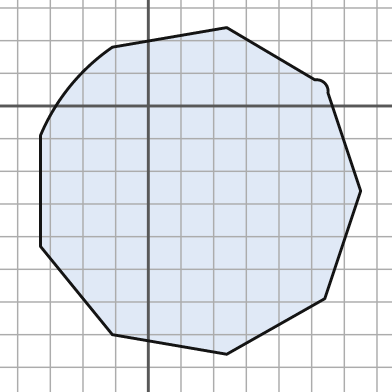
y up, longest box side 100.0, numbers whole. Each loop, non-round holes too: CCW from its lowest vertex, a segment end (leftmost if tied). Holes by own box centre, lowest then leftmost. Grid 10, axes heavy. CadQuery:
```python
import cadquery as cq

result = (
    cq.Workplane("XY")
    .moveTo(24.0, -76.0)
    .lineTo(54.0, -59.0)
    .lineTo(65.0, -26.0)
    .lineTo(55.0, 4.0)
    .threePointArc((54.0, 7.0), (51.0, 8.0))
    .lineTo(24.0, 24.0)
    .lineTo(-11.0, 18.0)
    .threePointArc((-24.0, 6.0), (-33.0, -9.0))
    .lineTo(-33.0, -43.0)
    .lineTo(-11.0, -70.0)
    .close()
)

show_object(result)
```